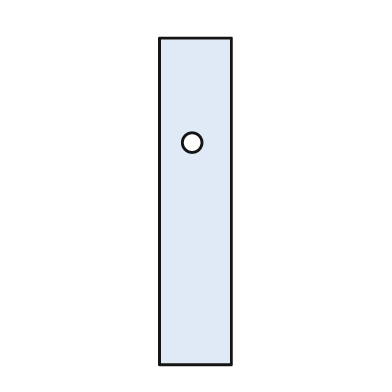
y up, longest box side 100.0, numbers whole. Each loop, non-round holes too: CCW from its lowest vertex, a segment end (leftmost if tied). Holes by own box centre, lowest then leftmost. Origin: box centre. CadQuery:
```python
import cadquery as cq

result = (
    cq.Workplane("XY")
    .moveTo(-11.0, -50.0)
    .lineTo(11.0, -50.0)
    .lineTo(11.0, 50.0)
    .lineTo(-11.0, 50.0)
    .close()
    .moveTo(-1.0, 18.0)
    .circle(3.0)
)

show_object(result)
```